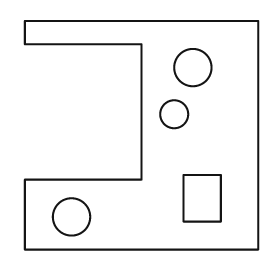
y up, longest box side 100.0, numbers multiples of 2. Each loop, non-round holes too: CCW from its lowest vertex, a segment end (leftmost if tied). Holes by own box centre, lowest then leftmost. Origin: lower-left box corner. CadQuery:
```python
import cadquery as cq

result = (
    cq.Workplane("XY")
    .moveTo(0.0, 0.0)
    .lineTo(100.0, 0.0)
    .lineTo(100.0, 98.0)
    .lineTo(0.0, 98.0)
    .lineTo(0.0, 88.0)
    .lineTo(50.0, 88.0)
    .lineTo(50.0, 30.0)
    .lineTo(0.0, 30.0)
    .close()
    .moveTo(20.0, 14.0)
    .circle(8.0)
    .moveTo(68.0, 12.0)
    .lineTo(84.0, 12.0)
    .lineTo(84.0, 32.0)
    .lineTo(68.0, 32.0)
    .close()
    .moveTo(64.0, 58.0)
    .circle(6.0)
    .moveTo(72.0, 78.0)
    .circle(8.0)
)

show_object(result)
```